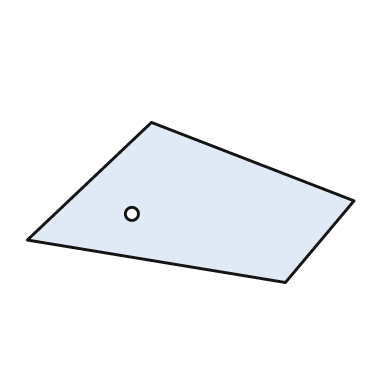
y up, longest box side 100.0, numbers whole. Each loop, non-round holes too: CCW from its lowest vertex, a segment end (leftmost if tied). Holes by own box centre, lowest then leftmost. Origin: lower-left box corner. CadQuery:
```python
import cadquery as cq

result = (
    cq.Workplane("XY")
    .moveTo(79.0, 0.0)
    .lineTo(100.0, 25.0)
    .lineTo(38.0, 49.0)
    .lineTo(0.0, 13.0)
    .close()
    .moveTo(32.0, 21.0)
    .circle(2.0)
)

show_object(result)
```